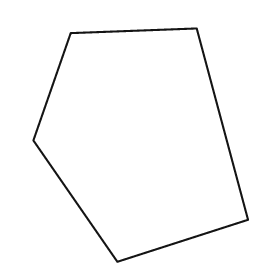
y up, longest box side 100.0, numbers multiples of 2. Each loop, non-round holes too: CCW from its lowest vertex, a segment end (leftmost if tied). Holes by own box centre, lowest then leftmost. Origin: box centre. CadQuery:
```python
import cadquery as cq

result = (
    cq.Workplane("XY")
    .moveTo(-10.0, -50.0)
    .lineTo(46.0, -32.0)
    .lineTo(24.0, 50.0)
    .lineTo(-30.0, 48.0)
    .lineTo(-46.0, 2.0)
    .close()
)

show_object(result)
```